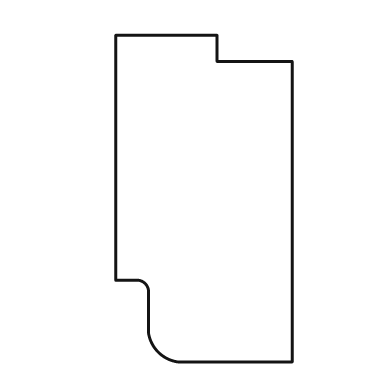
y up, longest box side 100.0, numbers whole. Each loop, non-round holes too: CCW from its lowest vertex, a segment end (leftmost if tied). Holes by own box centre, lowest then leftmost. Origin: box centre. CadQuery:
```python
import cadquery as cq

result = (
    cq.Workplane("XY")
    .moveTo(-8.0, -50.0)
    .lineTo(27.0, -50.0)
    .lineTo(27.0, 42.0)
    .lineTo(4.0, 42.0)
    .lineTo(4.0, 50.0)
    .lineTo(-27.0, 50.0)
    .lineTo(-27.0, -25.0)
    .lineTo(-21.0, -25.0)
    .threePointArc((-18.0, -26.0), (-17.0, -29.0))
    .lineTo(-17.0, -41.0)
    .threePointArc((-14.0, -47.0), (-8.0, -50.0))
    .close()
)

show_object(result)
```